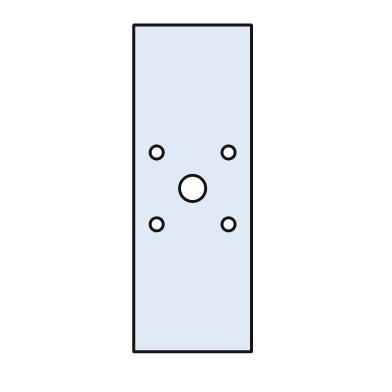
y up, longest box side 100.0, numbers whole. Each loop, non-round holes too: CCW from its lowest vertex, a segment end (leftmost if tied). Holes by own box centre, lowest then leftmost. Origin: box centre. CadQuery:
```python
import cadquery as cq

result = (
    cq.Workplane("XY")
    .moveTo(-18.0, -50.0)
    .lineTo(18.0, -50.0)
    .lineTo(18.0, 50.0)
    .lineTo(-18.0, 50.0)
    .close()
    .moveTo(-11.0, -11.0)
    .circle(2.0)
    .moveTo(11.0, -11.0)
    .circle(2.0)
    .moveTo(0.0, 0.0)
    .circle(4.0)
    .moveTo(-11.0, 11.0)
    .circle(2.0)
    .moveTo(11.0, 11.0)
    .circle(2.0)
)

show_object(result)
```